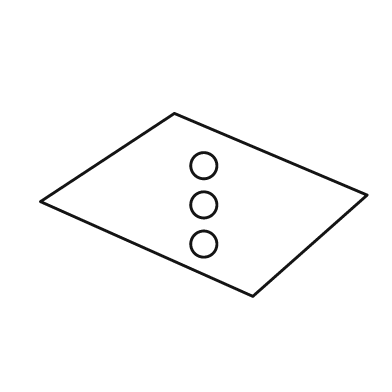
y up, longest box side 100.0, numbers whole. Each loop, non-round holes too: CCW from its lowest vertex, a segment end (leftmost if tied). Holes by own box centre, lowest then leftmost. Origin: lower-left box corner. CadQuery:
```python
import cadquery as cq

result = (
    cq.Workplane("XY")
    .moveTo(65.0, 0.0)
    .lineTo(100.0, 31.0)
    .lineTo(41.0, 56.0)
    .lineTo(0.0, 29.0)
    .close()
    .moveTo(50.0, 16.0)
    .circle(4.0)
    .moveTo(50.0, 28.0)
    .circle(4.0)
    .moveTo(50.0, 40.0)
    .circle(4.0)
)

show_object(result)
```